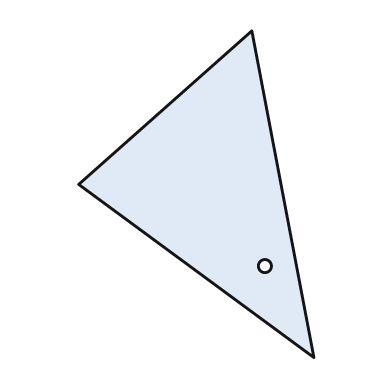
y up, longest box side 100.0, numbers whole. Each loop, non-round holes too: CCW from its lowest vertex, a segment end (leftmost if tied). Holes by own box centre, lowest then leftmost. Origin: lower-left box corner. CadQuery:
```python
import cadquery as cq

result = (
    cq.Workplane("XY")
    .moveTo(72.0, 0.0)
    .lineTo(53.0, 100.0)
    .lineTo(0.0, 53.0)
    .close()
    .moveTo(57.0, 28.0)
    .circle(2.0)
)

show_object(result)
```